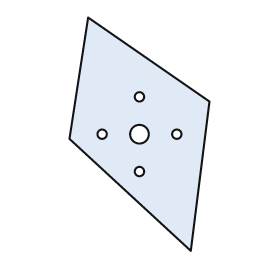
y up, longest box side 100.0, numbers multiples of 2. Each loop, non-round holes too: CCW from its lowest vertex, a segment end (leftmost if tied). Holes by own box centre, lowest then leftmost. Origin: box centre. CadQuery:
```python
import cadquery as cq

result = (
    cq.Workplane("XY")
    .moveTo(22.0, -50.0)
    .lineTo(30.0, 14.0)
    .lineTo(-22.0, 50.0)
    .lineTo(-30.0, -2.0)
    .close()
    .moveTo(0.0, -16.0)
    .circle(2.0)
    .moveTo(-16.0, 0.0)
    .circle(2.0)
    .moveTo(0.0, 0.0)
    .circle(4.0)
    .moveTo(16.0, 0.0)
    .circle(2.0)
    .moveTo(0.0, 16.0)
    .circle(2.0)
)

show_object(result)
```